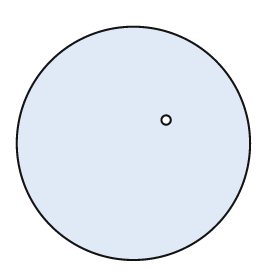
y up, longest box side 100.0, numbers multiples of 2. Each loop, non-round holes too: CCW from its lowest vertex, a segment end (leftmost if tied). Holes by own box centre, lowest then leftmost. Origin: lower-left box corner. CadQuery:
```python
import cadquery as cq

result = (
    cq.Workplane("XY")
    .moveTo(50.0, 50.0)
    .circle(50.0)
    .moveTo(64.0, 60.0)
    .circle(2.0)
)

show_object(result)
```